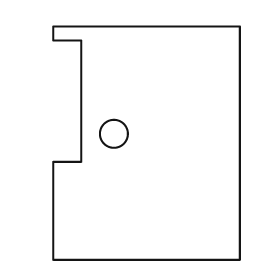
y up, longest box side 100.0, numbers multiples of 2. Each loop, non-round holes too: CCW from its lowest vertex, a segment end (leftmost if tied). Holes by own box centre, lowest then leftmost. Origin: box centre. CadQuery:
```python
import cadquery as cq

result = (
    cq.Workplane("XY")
    .moveTo(-40.0, -50.0)
    .lineTo(40.0, -50.0)
    .lineTo(40.0, 50.0)
    .lineTo(-40.0, 50.0)
    .lineTo(-40.0, 44.0)
    .lineTo(-28.0, 44.0)
    .lineTo(-28.0, -8.0)
    .lineTo(-40.0, -8.0)
    .close()
    .moveTo(-14.0, 4.0)
    .circle(6.0)
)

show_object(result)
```